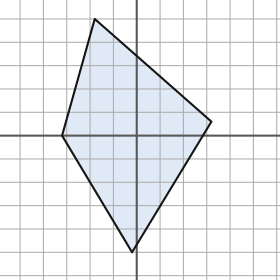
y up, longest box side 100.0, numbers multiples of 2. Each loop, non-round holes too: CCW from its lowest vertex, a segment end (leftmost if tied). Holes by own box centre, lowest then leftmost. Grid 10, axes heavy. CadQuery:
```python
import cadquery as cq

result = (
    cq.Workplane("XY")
    .moveTo(-2.0, -50.0)
    .lineTo(32.0, 6.0)
    .lineTo(-18.0, 50.0)
    .lineTo(-32.0, 0.0)
    .close()
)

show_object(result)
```